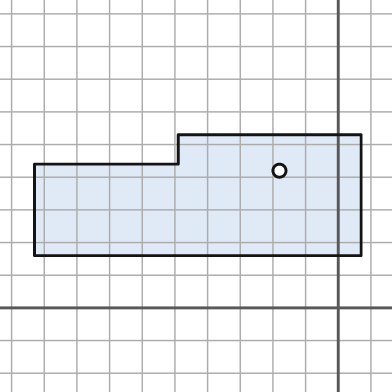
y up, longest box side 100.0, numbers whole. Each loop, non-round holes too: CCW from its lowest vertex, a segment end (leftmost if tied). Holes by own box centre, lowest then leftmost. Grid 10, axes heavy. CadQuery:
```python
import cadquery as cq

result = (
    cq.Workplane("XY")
    .moveTo(-93.0, 16.0)
    .lineTo(7.0, 16.0)
    .lineTo(7.0, 53.0)
    .lineTo(-49.0, 53.0)
    .lineTo(-49.0, 44.0)
    .lineTo(-93.0, 44.0)
    .close()
    .moveTo(-18.0, 42.0)
    .circle(2.0)
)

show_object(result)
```